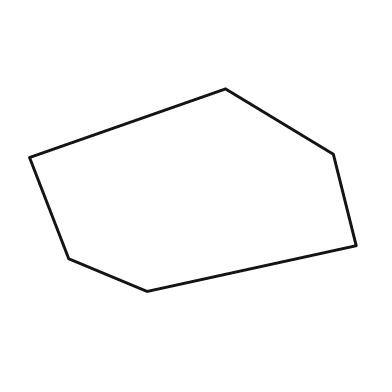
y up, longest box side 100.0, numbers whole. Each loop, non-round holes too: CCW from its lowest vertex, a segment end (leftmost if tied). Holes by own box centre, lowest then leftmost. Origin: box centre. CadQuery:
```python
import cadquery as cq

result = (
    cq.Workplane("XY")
    .moveTo(-14.0, -31.0)
    .lineTo(50.0, -17.0)
    .lineTo(43.0, 11.0)
    .lineTo(10.0, 31.0)
    .lineTo(-50.0, 10.0)
    .lineTo(-38.0, -21.0)
    .close()
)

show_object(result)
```